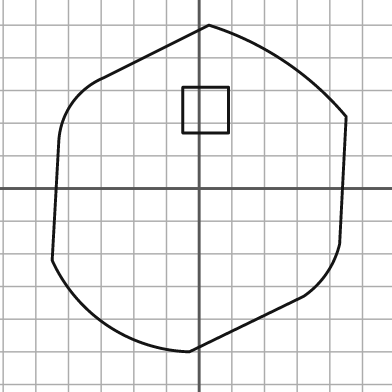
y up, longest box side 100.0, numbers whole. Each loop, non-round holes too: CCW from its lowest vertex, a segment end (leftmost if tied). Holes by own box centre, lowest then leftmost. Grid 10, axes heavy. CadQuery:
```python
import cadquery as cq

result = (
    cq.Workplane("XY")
    .moveTo(-3.0, -50.0)
    .lineTo(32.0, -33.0)
    .threePointArc((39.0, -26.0), (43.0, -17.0))
    .lineTo(45.0, 22.0)
    .threePointArc((26.0, 39.0), (3.0, 50.0))
    .lineTo(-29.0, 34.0)
    .threePointArc((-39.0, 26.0), (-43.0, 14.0))
    .lineTo(-45.0, -22.0)
    .threePointArc((-28.0, -42.0), (-3.0, -50.0))
    .close()
    .moveTo(-5.0, 17.0)
    .lineTo(9.0, 17.0)
    .lineTo(9.0, 31.0)
    .lineTo(-5.0, 31.0)
    .close()
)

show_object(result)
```